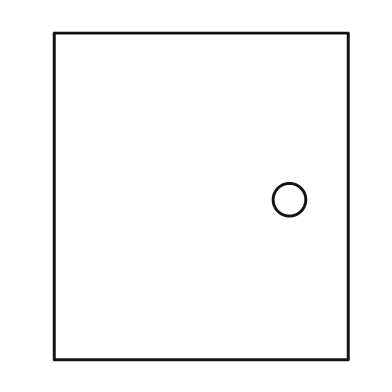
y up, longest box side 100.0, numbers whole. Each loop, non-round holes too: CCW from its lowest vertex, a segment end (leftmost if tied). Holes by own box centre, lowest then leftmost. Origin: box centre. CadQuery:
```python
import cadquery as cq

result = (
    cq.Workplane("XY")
    .moveTo(-45.0, -50.0)
    .lineTo(45.0, -50.0)
    .lineTo(45.0, 50.0)
    .lineTo(-45.0, 50.0)
    .close()
    .moveTo(27.0, -1.0)
    .circle(5.0)
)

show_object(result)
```